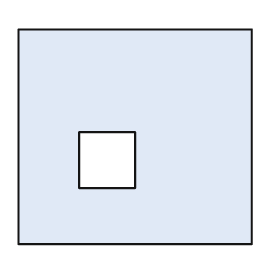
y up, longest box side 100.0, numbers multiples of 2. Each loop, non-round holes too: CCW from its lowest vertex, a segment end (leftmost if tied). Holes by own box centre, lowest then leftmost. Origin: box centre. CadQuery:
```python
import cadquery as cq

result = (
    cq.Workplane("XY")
    .moveTo(-50.0, -46.0)
    .lineTo(50.0, -46.0)
    .lineTo(50.0, 46.0)
    .lineTo(-50.0, 46.0)
    .close()
    .moveTo(-24.0, -22.0)
    .lineTo(0.0, -22.0)
    .lineTo(0.0, 2.0)
    .lineTo(-24.0, 2.0)
    .close()
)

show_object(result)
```